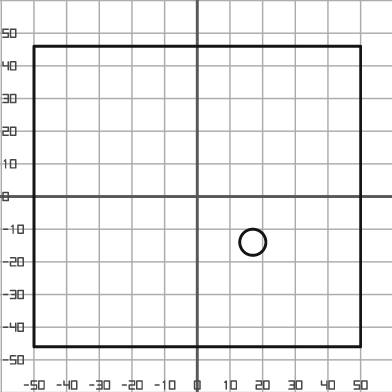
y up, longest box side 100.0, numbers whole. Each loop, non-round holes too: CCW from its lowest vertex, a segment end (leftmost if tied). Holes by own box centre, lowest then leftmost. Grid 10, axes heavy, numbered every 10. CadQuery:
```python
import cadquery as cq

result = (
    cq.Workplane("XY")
    .moveTo(-50.0, -46.0)
    .lineTo(50.0, -46.0)
    .lineTo(50.0, 46.0)
    .lineTo(-50.0, 46.0)
    .close()
    .moveTo(17.0, -14.0)
    .circle(4.0)
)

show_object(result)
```